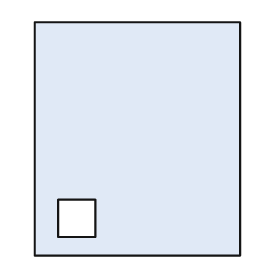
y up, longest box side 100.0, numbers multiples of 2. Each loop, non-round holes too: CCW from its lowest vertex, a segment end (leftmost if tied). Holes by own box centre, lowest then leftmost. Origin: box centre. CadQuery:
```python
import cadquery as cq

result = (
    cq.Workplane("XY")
    .moveTo(-44.0, -50.0)
    .lineTo(44.0, -50.0)
    .lineTo(44.0, 50.0)
    .lineTo(-44.0, 50.0)
    .close()
    .moveTo(-34.0, -42.0)
    .lineTo(-18.0, -42.0)
    .lineTo(-18.0, -26.0)
    .lineTo(-34.0, -26.0)
    .close()
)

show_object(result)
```